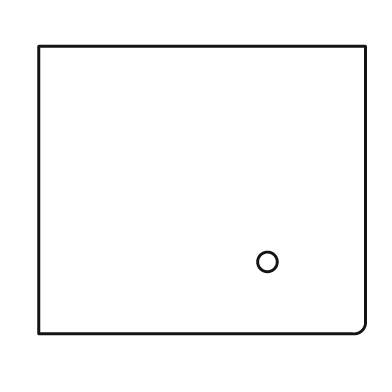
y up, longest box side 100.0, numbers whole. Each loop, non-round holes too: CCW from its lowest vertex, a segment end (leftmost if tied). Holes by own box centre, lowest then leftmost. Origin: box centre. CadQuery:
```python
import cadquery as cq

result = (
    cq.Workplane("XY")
    .moveTo(-50.0, -44.0)
    .lineTo(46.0, -44.0)
    .threePointArc((49.0, -43.0), (50.0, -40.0))
    .lineTo(50.0, 44.0)
    .lineTo(-50.0, 44.0)
    .close()
    .moveTo(20.0, -22.0)
    .circle(3.0)
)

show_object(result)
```